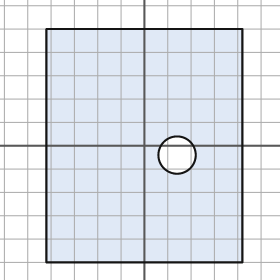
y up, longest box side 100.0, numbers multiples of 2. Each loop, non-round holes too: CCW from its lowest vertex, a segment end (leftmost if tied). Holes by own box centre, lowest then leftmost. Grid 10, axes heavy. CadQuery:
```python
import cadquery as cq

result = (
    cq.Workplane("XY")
    .moveTo(-42.0, -50.0)
    .lineTo(42.0, -50.0)
    .lineTo(42.0, 50.0)
    .lineTo(-42.0, 50.0)
    .close()
    .moveTo(14.0, -4.0)
    .circle(8.0)
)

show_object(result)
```